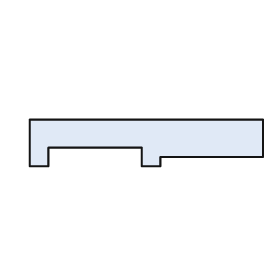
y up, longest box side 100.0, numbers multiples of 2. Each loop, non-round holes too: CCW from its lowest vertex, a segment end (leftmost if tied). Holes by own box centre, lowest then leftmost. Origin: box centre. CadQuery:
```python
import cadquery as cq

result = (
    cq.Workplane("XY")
    .moveTo(-50.0, -10.0)
    .lineTo(-42.0, -10.0)
    .lineTo(-42.0, -2.0)
    .lineTo(-2.0, -2.0)
    .lineTo(-2.0, -10.0)
    .lineTo(6.0, -10.0)
    .lineTo(6.0, -6.0)
    .lineTo(50.0, -6.0)
    .lineTo(50.0, 10.0)
    .lineTo(-50.0, 10.0)
    .close()
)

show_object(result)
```